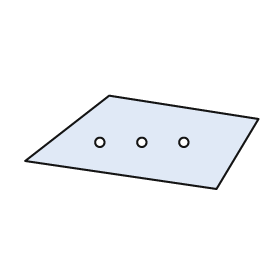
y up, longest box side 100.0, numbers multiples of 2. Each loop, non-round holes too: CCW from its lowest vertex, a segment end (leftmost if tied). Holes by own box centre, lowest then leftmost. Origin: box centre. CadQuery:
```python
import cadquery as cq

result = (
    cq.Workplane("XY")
    .moveTo(32.0, -20.0)
    .lineTo(50.0, 10.0)
    .lineTo(-14.0, 20.0)
    .lineTo(-50.0, -8.0)
    .close()
    .moveTo(-18.0, 0.0)
    .circle(2.0)
    .moveTo(0.0, 0.0)
    .circle(2.0)
    .moveTo(18.0, 0.0)
    .circle(2.0)
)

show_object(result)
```